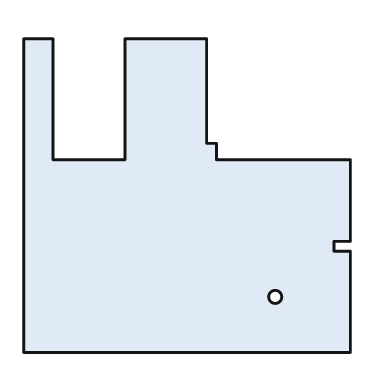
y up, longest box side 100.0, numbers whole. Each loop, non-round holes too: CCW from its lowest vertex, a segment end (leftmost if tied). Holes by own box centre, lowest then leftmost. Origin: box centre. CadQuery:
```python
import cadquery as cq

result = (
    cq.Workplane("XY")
    .moveTo(-50.0, -48.0)
    .lineTo(50.0, -48.0)
    .lineTo(50.0, -17.0)
    .lineTo(45.0, -17.0)
    .lineTo(45.0, -14.0)
    .lineTo(50.0, -14.0)
    .lineTo(50.0, 11.0)
    .lineTo(9.0, 11.0)
    .lineTo(9.0, 16.0)
    .lineTo(6.0, 16.0)
    .lineTo(6.0, 48.0)
    .lineTo(-19.0, 48.0)
    .lineTo(-19.0, 11.0)
    .lineTo(-41.0, 11.0)
    .lineTo(-41.0, 48.0)
    .lineTo(-50.0, 48.0)
    .close()
    .moveTo(27.0, -31.0)
    .circle(2.0)
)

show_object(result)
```